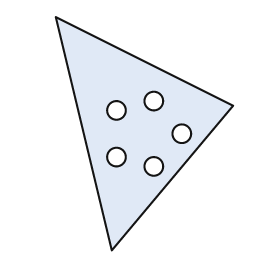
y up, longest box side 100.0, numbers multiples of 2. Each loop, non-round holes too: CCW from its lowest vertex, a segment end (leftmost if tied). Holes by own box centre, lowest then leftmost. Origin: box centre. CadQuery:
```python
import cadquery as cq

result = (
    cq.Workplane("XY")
    .moveTo(-14.0, -50.0)
    .lineTo(38.0, 12.0)
    .lineTo(-38.0, 50.0)
    .close()
    .moveTo(4.0, -14.0)
    .circle(4.0)
    .moveTo(-12.0, -10.0)
    .circle(4.0)
    .moveTo(16.0, 0.0)
    .circle(4.0)
    .moveTo(-12.0, 10.0)
    .circle(4.0)
    .moveTo(4.0, 14.0)
    .circle(4.0)
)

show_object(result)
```